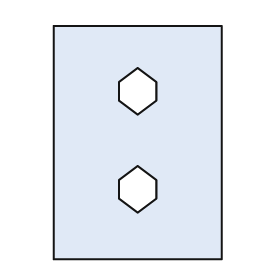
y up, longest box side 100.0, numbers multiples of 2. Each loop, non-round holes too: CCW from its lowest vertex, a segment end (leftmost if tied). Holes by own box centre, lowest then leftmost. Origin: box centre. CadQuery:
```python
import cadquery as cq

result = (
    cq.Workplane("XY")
    .moveTo(-36.0, -50.0)
    .lineTo(36.0, -50.0)
    .lineTo(36.0, 50.0)
    .lineTo(-36.0, 50.0)
    .close()
    .moveTo(0.0, -30.0)
    .lineTo(8.0, -24.0)
    .lineTo(8.0, -16.0)
    .lineTo(0.0, -10.0)
    .lineTo(-8.0, -16.0)
    .lineTo(-8.0, -24.0)
    .close()
    .moveTo(0.0, 12.0)
    .lineTo(8.0, 18.0)
    .lineTo(8.0, 26.0)
    .lineTo(0.0, 32.0)
    .lineTo(-8.0, 26.0)
    .lineTo(-8.0, 18.0)
    .close()
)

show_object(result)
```